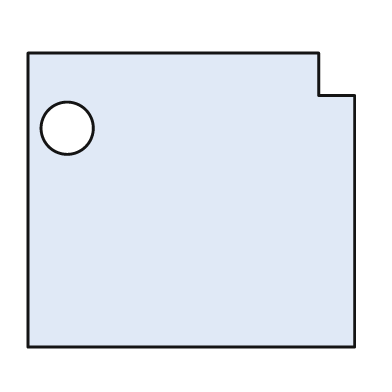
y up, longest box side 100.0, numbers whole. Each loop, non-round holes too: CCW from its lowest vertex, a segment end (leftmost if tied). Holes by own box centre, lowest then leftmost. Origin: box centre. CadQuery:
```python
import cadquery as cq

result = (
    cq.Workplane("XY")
    .moveTo(-50.0, -45.0)
    .lineTo(50.0, -45.0)
    .lineTo(50.0, 32.0)
    .lineTo(39.0, 32.0)
    .lineTo(39.0, 45.0)
    .lineTo(-50.0, 45.0)
    .close()
    .moveTo(-38.0, 22.0)
    .circle(8.0)
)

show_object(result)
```